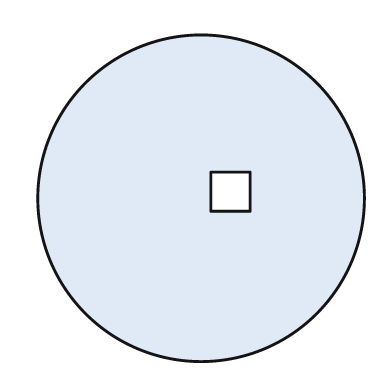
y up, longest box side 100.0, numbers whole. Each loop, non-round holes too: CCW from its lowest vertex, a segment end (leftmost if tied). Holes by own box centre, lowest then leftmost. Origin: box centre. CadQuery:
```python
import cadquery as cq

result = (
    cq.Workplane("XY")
    .moveTo(0.0, 0.0)
    .circle(50.0)
    .moveTo(3.0, -4.0)
    .lineTo(15.0, -4.0)
    .lineTo(15.0, 8.0)
    .lineTo(3.0, 8.0)
    .close()
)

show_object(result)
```